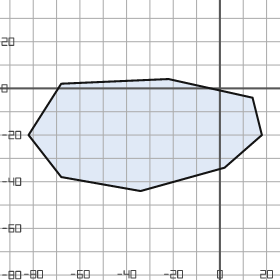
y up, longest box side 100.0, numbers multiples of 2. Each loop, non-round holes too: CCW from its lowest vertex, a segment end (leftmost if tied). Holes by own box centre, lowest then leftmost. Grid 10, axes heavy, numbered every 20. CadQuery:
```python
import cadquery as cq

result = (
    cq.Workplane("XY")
    .moveTo(-34.0, -44.0)
    .lineTo(2.0, -34.0)
    .lineTo(18.0, -20.0)
    .lineTo(14.0, -4.0)
    .lineTo(-22.0, 4.0)
    .lineTo(-68.0, 2.0)
    .lineTo(-82.0, -20.0)
    .lineTo(-68.0, -38.0)
    .close()
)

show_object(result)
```